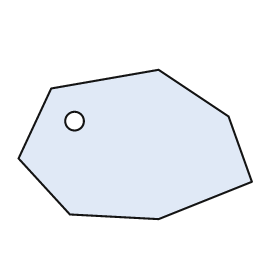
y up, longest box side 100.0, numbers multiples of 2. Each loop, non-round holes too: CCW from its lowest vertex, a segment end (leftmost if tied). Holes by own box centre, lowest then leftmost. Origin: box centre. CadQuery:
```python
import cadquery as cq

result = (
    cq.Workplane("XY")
    .moveTo(10.0, -32.0)
    .lineTo(50.0, -16.0)
    .lineTo(40.0, 12.0)
    .lineTo(10.0, 32.0)
    .lineTo(-36.0, 24.0)
    .lineTo(-50.0, -6.0)
    .lineTo(-28.0, -30.0)
    .close()
    .moveTo(-26.0, 10.0)
    .circle(4.0)
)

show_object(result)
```